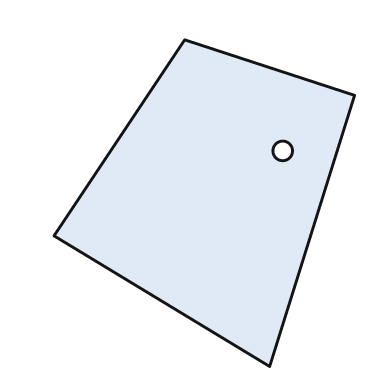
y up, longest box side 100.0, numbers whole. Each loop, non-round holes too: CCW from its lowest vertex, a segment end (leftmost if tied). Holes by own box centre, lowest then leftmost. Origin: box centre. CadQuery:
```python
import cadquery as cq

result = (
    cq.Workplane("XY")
    .moveTo(20.0, -50.0)
    .lineTo(46.0, 33.0)
    .lineTo(-6.0, 50.0)
    .lineTo(-46.0, -10.0)
    .close()
    .moveTo(24.0, 16.0)
    .circle(3.0)
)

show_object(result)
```